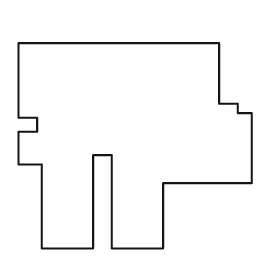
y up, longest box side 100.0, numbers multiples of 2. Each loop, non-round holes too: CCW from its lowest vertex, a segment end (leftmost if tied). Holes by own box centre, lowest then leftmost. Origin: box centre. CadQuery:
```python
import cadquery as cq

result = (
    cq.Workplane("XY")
    .moveTo(-40.0, -44.0)
    .lineTo(-18.0, -44.0)
    .lineTo(-18.0, -4.0)
    .lineTo(-10.0, -4.0)
    .lineTo(-10.0, -44.0)
    .lineTo(12.0, -44.0)
    .lineTo(12.0, -16.0)
    .lineTo(50.0, -16.0)
    .lineTo(50.0, 14.0)
    .lineTo(44.0, 14.0)
    .lineTo(44.0, 18.0)
    .lineTo(36.0, 18.0)
    .lineTo(36.0, 44.0)
    .lineTo(-50.0, 44.0)
    .lineTo(-50.0, 12.0)
    .lineTo(-42.0, 12.0)
    .lineTo(-42.0, 6.0)
    .lineTo(-50.0, 6.0)
    .lineTo(-50.0, -8.0)
    .lineTo(-40.0, -8.0)
    .close()
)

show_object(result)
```